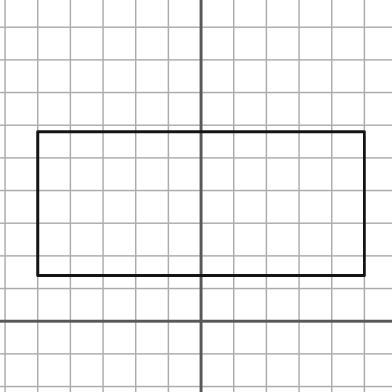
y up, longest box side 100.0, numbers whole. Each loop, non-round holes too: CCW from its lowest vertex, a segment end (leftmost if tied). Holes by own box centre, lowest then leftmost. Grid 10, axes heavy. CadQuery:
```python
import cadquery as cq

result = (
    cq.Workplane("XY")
    .moveTo(-50.0, 14.0)
    .lineTo(50.0, 14.0)
    .lineTo(50.0, 58.0)
    .lineTo(-50.0, 58.0)
    .close()
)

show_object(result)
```